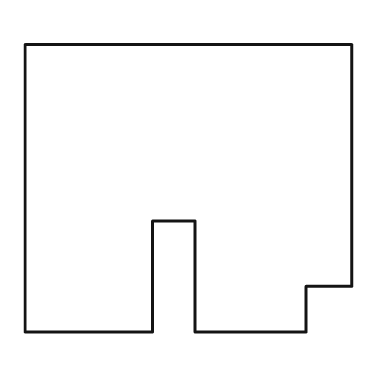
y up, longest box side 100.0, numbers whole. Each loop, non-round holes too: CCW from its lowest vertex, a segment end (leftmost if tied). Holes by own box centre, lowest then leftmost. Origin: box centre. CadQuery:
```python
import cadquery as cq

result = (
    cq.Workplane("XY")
    .moveTo(-50.0, -44.0)
    .lineTo(-11.0, -44.0)
    .lineTo(-11.0, -10.0)
    .lineTo(2.0, -10.0)
    .lineTo(2.0, -44.0)
    .lineTo(36.0, -44.0)
    .lineTo(36.0, -30.0)
    .lineTo(50.0, -30.0)
    .lineTo(50.0, 44.0)
    .lineTo(-50.0, 44.0)
    .close()
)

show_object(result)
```